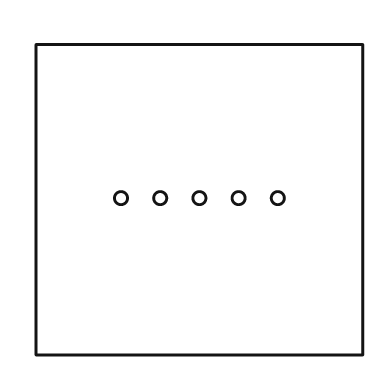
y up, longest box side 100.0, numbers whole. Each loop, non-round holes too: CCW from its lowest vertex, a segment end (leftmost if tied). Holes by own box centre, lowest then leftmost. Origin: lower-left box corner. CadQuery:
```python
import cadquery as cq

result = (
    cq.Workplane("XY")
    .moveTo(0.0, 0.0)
    .lineTo(100.0, 0.0)
    .lineTo(100.0, 95.0)
    .lineTo(0.0, 95.0)
    .close()
    .moveTo(26.0, 48.0)
    .circle(2.0)
    .moveTo(38.0, 48.0)
    .circle(2.0)
    .moveTo(50.0, 48.0)
    .circle(2.0)
    .moveTo(62.0, 48.0)
    .circle(2.0)
    .moveTo(74.0, 48.0)
    .circle(2.0)
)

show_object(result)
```